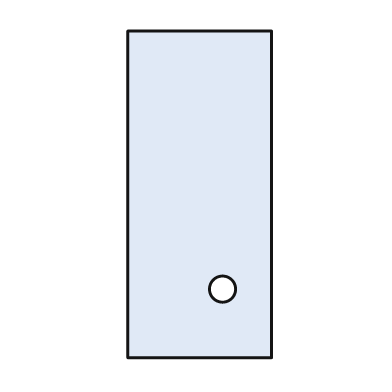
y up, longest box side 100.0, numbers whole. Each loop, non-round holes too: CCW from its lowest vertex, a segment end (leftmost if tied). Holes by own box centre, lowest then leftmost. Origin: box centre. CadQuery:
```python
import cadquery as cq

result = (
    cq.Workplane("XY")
    .moveTo(-22.0, -50.0)
    .lineTo(22.0, -50.0)
    .lineTo(22.0, 50.0)
    .lineTo(-22.0, 50.0)
    .close()
    .moveTo(7.0, -29.0)
    .circle(4.0)
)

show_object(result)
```